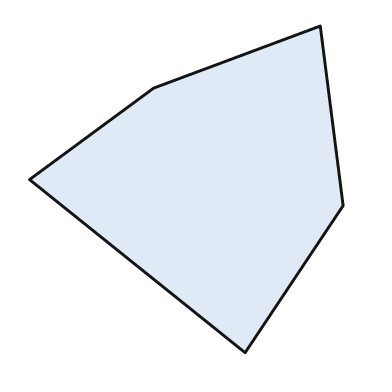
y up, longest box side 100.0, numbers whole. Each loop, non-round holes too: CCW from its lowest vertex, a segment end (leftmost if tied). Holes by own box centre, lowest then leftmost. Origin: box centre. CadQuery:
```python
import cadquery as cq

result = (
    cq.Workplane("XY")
    .moveTo(18.0, -50.0)
    .lineTo(48.0, -5.0)
    .lineTo(41.0, 50.0)
    .lineTo(-10.0, 31.0)
    .lineTo(-48.0, 3.0)
    .close()
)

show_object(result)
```